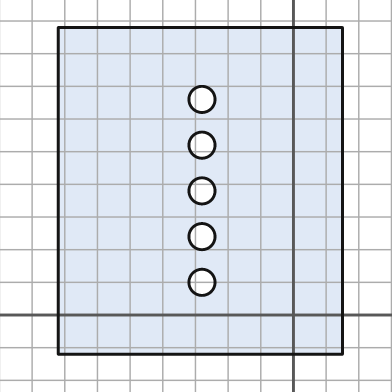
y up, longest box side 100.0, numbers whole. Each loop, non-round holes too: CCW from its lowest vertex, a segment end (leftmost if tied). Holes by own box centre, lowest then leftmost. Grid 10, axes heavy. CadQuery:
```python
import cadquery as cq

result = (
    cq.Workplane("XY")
    .moveTo(-72.0, -12.0)
    .lineTo(15.0, -12.0)
    .lineTo(15.0, 88.0)
    .lineTo(-72.0, 88.0)
    .close()
    .moveTo(-28.0, 10.0)
    .circle(4.0)
    .moveTo(-28.0, 24.0)
    .circle(4.0)
    .moveTo(-28.0, 38.0)
    .circle(4.0)
    .moveTo(-28.0, 52.0)
    .circle(4.0)
    .moveTo(-28.0, 66.0)
    .circle(4.0)
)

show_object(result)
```